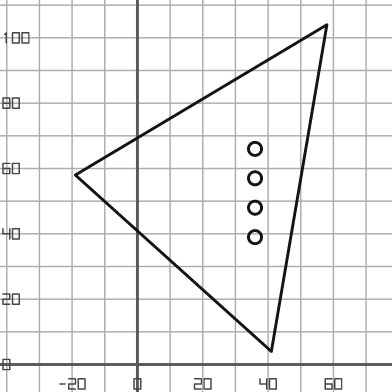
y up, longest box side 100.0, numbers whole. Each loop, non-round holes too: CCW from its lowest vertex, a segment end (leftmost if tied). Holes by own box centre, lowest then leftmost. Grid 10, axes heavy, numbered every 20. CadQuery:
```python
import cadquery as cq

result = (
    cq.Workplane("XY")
    .moveTo(41.0, 4.0)
    .lineTo(58.0, 104.0)
    .lineTo(-19.0, 58.0)
    .close()
    .moveTo(36.0, 39.0)
    .circle(2.0)
    .moveTo(36.0, 48.0)
    .circle(2.0)
    .moveTo(36.0, 57.0)
    .circle(2.0)
    .moveTo(36.0, 66.0)
    .circle(2.0)
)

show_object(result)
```